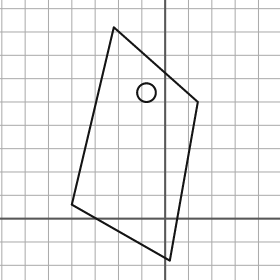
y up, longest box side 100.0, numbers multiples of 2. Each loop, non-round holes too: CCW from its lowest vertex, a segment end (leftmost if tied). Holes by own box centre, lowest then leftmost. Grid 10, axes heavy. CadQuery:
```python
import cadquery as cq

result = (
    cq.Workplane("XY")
    .moveTo(2.0, -18.0)
    .lineTo(14.0, 50.0)
    .lineTo(-22.0, 82.0)
    .lineTo(-40.0, 6.0)
    .close()
    .moveTo(-8.0, 54.0)
    .circle(4.0)
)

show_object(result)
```